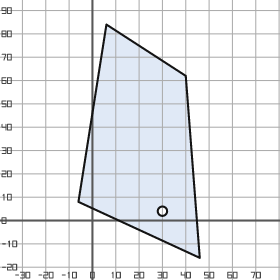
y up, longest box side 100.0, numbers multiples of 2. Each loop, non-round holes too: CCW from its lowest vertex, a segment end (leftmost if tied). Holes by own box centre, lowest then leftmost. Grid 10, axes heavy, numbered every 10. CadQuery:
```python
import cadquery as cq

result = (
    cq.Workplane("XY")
    .moveTo(46.0, -16.0)
    .lineTo(40.0, 62.0)
    .lineTo(6.0, 84.0)
    .lineTo(-6.0, 8.0)
    .close()
    .moveTo(30.0, 4.0)
    .circle(2.0)
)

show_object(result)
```